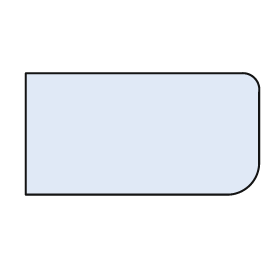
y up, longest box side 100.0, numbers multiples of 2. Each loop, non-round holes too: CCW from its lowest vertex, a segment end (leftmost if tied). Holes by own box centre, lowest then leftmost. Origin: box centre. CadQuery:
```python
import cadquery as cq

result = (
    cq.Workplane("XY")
    .moveTo(-50.0, -26.0)
    .lineTo(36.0, -26.0)
    .threePointArc((46.0, -22.0), (50.0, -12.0))
    .lineTo(50.0, 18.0)
    .threePointArc((48.0, 24.0), (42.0, 26.0))
    .lineTo(-50.0, 26.0)
    .close()
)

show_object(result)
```